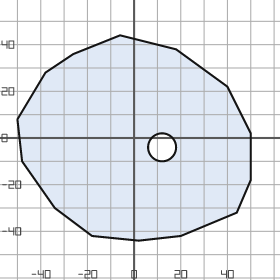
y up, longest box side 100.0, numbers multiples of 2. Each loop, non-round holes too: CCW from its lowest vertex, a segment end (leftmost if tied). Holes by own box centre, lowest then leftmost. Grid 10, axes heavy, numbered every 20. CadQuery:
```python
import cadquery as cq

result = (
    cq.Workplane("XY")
    .moveTo(2.0, -44.0)
    .lineTo(20.0, -42.0)
    .lineTo(44.0, -32.0)
    .lineTo(50.0, -18.0)
    .lineTo(50.0, 2.0)
    .lineTo(40.0, 22.0)
    .lineTo(18.0, 38.0)
    .lineTo(-6.0, 44.0)
    .lineTo(-26.0, 36.0)
    .lineTo(-38.0, 28.0)
    .lineTo(-50.0, 8.0)
    .lineTo(-48.0, -10.0)
    .lineTo(-34.0, -30.0)
    .lineTo(-18.0, -42.0)
    .close()
    .moveTo(12.0, -4.0)
    .circle(6.0)
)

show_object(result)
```